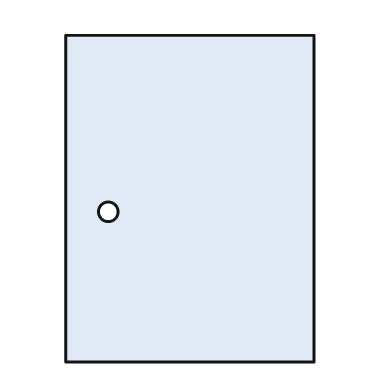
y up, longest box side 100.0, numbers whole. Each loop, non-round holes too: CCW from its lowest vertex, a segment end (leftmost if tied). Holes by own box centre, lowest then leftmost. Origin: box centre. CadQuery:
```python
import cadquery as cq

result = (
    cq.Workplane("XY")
    .moveTo(-38.0, -50.0)
    .lineTo(38.0, -50.0)
    .lineTo(38.0, 50.0)
    .lineTo(-38.0, 50.0)
    .close()
    .moveTo(-25.0, -4.0)
    .circle(3.0)
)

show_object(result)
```